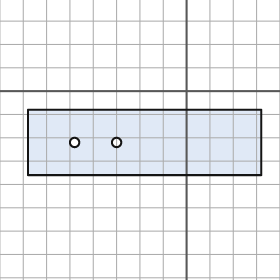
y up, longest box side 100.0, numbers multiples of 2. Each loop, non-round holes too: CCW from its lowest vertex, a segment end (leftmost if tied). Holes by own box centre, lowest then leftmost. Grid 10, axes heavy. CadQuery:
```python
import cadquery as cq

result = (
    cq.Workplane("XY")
    .moveTo(-68.0, -36.0)
    .lineTo(32.0, -36.0)
    .lineTo(32.0, -8.0)
    .lineTo(-68.0, -8.0)
    .close()
    .moveTo(-48.0, -22.0)
    .circle(2.0)
    .moveTo(-30.0, -22.0)
    .circle(2.0)
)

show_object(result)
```